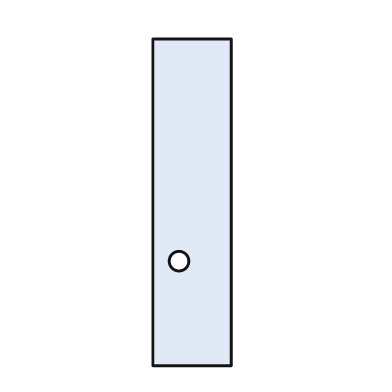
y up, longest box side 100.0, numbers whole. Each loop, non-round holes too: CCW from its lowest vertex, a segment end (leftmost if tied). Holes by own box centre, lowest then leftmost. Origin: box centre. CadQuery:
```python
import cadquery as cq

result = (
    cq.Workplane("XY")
    .moveTo(-12.0, -50.0)
    .lineTo(12.0, -50.0)
    .lineTo(12.0, 50.0)
    .lineTo(-12.0, 50.0)
    .close()
    .moveTo(-4.0, -18.0)
    .circle(3.0)
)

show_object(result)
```